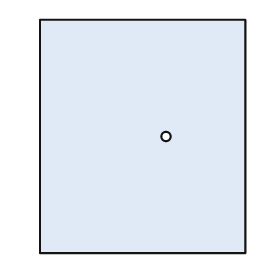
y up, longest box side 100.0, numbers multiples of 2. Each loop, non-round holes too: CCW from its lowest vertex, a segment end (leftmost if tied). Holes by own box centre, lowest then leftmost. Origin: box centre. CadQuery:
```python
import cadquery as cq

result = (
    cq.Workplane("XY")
    .moveTo(-44.0, -50.0)
    .lineTo(44.0, -50.0)
    .lineTo(44.0, 50.0)
    .lineTo(-44.0, 50.0)
    .close()
    .moveTo(10.0, 0.0)
    .circle(2.0)
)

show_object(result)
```